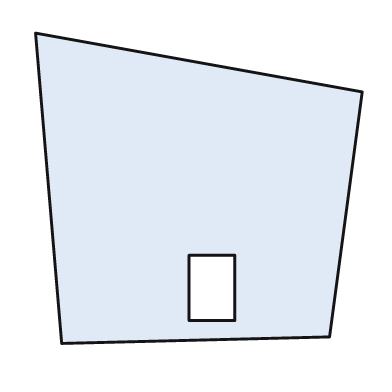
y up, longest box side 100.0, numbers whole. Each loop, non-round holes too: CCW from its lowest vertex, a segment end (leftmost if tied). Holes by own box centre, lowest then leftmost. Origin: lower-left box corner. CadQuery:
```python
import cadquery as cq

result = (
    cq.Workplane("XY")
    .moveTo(8.0, 0.0)
    .lineTo(90.0, 2.0)
    .lineTo(100.0, 77.0)
    .lineTo(0.0, 95.0)
    .close()
    .moveTo(47.0, 7.0)
    .lineTo(61.0, 7.0)
    .lineTo(61.0, 27.0)
    .lineTo(47.0, 27.0)
    .close()
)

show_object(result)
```